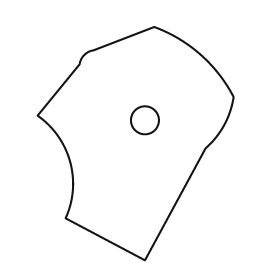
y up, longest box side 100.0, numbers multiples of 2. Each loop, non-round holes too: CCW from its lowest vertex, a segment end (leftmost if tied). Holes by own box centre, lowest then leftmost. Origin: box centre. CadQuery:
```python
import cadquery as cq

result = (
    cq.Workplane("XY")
    .moveTo(4.0, -50.0)
    .lineTo(30.0, -2.0)
    .threePointArc((38.0, 8.0), (42.0, 20.0))
    .threePointArc((28.0, 38.0), (8.0, 50.0))
    .lineTo(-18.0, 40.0)
    .threePointArc((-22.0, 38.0), (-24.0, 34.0))
    .lineTo(-42.0, 12.0)
    .threePointArc((-28.0, -8.0), (-30.0, -32.0))
    .close()
    .moveTo(4.0, 10.0)
    .circle(6.0)
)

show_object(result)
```